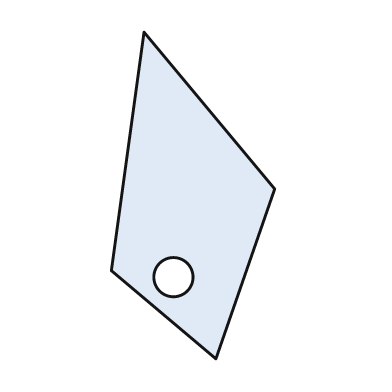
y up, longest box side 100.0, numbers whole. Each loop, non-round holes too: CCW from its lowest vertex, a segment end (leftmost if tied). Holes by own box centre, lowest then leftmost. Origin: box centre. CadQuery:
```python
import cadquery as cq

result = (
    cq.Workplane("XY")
    .moveTo(7.0, -50.0)
    .lineTo(25.0, 2.0)
    .lineTo(-15.0, 50.0)
    .lineTo(-25.0, -23.0)
    .close()
    .moveTo(-6.0, -25.0)
    .circle(6.0)
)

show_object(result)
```